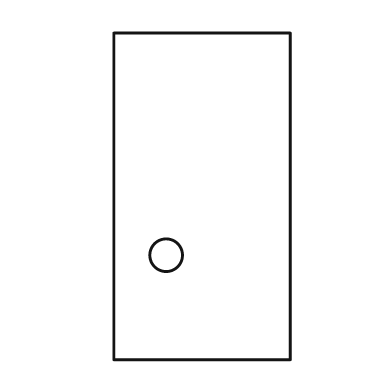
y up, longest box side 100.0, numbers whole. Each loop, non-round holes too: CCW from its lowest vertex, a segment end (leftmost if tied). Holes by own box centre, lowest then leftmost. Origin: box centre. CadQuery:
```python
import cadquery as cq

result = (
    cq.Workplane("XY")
    .moveTo(-27.0, -50.0)
    .lineTo(27.0, -50.0)
    .lineTo(27.0, 50.0)
    .lineTo(-27.0, 50.0)
    .close()
    .moveTo(-11.0, -18.0)
    .circle(5.0)
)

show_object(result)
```